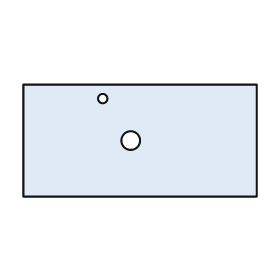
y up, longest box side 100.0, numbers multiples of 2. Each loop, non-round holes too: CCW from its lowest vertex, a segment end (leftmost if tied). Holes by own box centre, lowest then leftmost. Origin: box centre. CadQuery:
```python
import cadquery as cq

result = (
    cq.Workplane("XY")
    .moveTo(-50.0, -24.0)
    .lineTo(50.0, -24.0)
    .lineTo(50.0, 24.0)
    .lineTo(-50.0, 24.0)
    .close()
    .moveTo(-4.0, 0.0)
    .circle(4.0)
    .moveTo(-16.0, 18.0)
    .circle(2.0)
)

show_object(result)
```